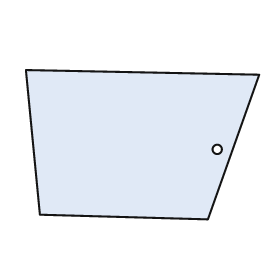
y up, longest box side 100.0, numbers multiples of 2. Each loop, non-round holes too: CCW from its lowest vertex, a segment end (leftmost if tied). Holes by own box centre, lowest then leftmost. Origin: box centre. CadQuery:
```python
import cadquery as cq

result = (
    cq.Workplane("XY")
    .moveTo(28.0, -32.0)
    .lineTo(50.0, 30.0)
    .lineTo(-50.0, 32.0)
    .lineTo(-44.0, -30.0)
    .close()
    .moveTo(32.0, -2.0)
    .circle(2.0)
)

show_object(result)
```